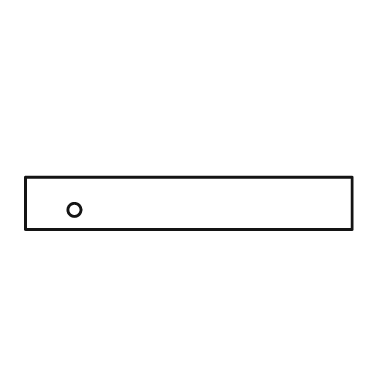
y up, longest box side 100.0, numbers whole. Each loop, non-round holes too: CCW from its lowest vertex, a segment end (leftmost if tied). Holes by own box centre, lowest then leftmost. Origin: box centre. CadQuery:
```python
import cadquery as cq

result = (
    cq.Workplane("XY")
    .moveTo(-50.0, -8.0)
    .lineTo(50.0, -8.0)
    .lineTo(50.0, 8.0)
    .lineTo(-50.0, 8.0)
    .close()
    .moveTo(-35.0, -2.0)
    .circle(2.0)
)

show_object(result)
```